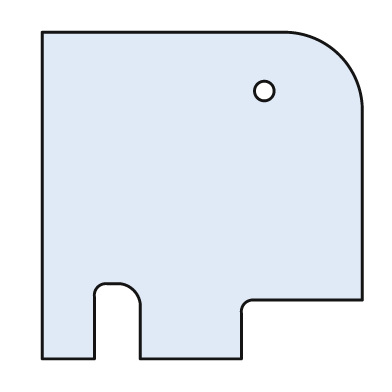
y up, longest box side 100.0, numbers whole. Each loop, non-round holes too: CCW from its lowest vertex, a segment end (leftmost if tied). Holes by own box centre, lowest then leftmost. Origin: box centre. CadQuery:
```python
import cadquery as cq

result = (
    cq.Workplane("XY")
    .moveTo(-49.0, -50.0)
    .lineTo(-33.0, -50.0)
    .lineTo(-33.0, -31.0)
    .threePointArc((-32.0, -28.0), (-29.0, -27.0))
    .lineTo(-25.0, -27.0)
    .threePointArc((-21.0, -29.0), (-19.0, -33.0))
    .lineTo(-19.0, -50.0)
    .lineTo(12.0, -50.0)
    .lineTo(12.0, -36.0)
    .threePointArc((13.0, -33.0), (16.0, -32.0))
    .lineTo(49.0, -32.0)
    .lineTo(49.0, 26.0)
    .threePointArc((42.0, 43.0), (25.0, 50.0))
    .lineTo(-49.0, 50.0)
    .close()
    .moveTo(19.0, 32.0)
    .circle(3.0)
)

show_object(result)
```